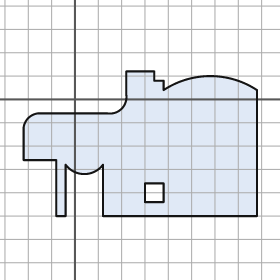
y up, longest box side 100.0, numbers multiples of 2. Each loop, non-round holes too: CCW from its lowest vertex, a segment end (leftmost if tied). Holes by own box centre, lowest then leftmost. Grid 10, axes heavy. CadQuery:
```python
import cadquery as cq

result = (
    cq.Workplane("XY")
    .moveTo(-8.0, -50.0)
    .lineTo(-4.0, -50.0)
    .lineTo(-4.0, -28.0)
    .threePointArc((4.0, -32.0), (12.0, -28.0))
    .lineTo(12.0, -50.0)
    .lineTo(78.0, -50.0)
    .lineTo(78.0, 4.0)
    .threePointArc((58.0, 10.0), (38.0, 4.0))
    .lineTo(38.0, 8.0)
    .lineTo(34.0, 8.0)
    .lineTo(34.0, 12.0)
    .lineTo(22.0, 12.0)
    .lineTo(22.0, 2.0)
    .threePointArc((20.0, -4.0), (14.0, -6.0))
    .lineTo(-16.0, -6.0)
    .threePointArc((-20.0, -8.0), (-22.0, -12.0))
    .lineTo(-22.0, -26.0)
    .lineTo(-8.0, -26.0)
    .close()
    .moveTo(30.0, -44.0)
    .lineTo(38.0, -44.0)
    .lineTo(38.0, -36.0)
    .lineTo(30.0, -36.0)
    .close()
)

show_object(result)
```